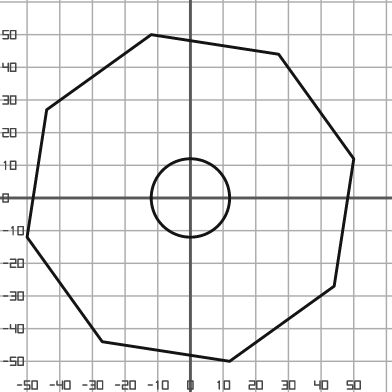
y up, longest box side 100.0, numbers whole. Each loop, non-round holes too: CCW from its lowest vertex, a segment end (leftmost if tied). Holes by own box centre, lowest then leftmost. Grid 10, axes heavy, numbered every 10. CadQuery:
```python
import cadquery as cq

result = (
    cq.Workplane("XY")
    .moveTo(12.0, -50.0)
    .lineTo(44.0, -27.0)
    .lineTo(50.0, 12.0)
    .lineTo(27.0, 44.0)
    .lineTo(-12.0, 50.0)
    .lineTo(-44.0, 27.0)
    .lineTo(-50.0, -12.0)
    .lineTo(-27.0, -44.0)
    .close()
    .moveTo(0.0, 0.0)
    .circle(12.0)
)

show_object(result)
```